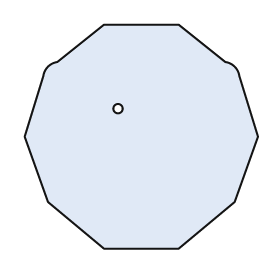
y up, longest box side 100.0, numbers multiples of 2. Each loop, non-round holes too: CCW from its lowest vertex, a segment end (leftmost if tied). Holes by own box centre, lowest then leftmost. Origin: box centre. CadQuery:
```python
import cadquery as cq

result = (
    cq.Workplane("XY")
    .moveTo(-16.0, -48.0)
    .lineTo(16.0, -48.0)
    .lineTo(40.0, -28.0)
    .lineTo(50.0, 0.0)
    .lineTo(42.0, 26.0)
    .threePointArc((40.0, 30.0), (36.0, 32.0))
    .lineTo(16.0, 48.0)
    .lineTo(-16.0, 48.0)
    .lineTo(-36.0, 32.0)
    .threePointArc((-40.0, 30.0), (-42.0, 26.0))
    .lineTo(-50.0, 0.0)
    .lineTo(-40.0, -28.0)
    .close()
    .moveTo(-10.0, 12.0)
    .circle(2.0)
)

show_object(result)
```